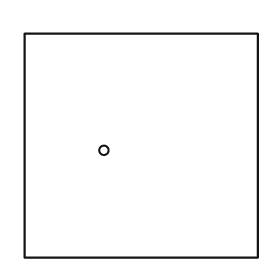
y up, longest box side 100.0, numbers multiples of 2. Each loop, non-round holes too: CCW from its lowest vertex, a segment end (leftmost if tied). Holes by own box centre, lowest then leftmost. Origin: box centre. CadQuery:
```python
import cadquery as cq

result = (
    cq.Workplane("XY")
    .moveTo(-50.0, -48.0)
    .lineTo(50.0, -48.0)
    .lineTo(50.0, 48.0)
    .lineTo(-50.0, 48.0)
    .close()
    .moveTo(-16.0, -2.0)
    .circle(2.0)
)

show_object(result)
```